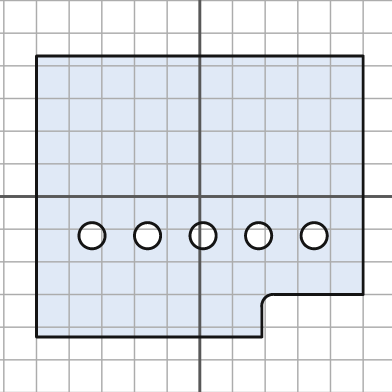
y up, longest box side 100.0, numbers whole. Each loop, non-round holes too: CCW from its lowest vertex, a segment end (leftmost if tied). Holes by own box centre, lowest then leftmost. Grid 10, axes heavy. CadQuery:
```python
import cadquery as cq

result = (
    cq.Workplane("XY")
    .moveTo(-50.0, -43.0)
    .lineTo(19.0, -43.0)
    .lineTo(19.0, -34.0)
    .threePointArc((20.0, -31.0), (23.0, -30.0))
    .lineTo(50.0, -30.0)
    .lineTo(50.0, 43.0)
    .lineTo(-50.0, 43.0)
    .close()
    .moveTo(-33.0, -12.0)
    .circle(4.0)
    .moveTo(-16.0, -12.0)
    .circle(4.0)
    .moveTo(1.0, -12.0)
    .circle(4.0)
    .moveTo(18.0, -12.0)
    .circle(4.0)
    .moveTo(35.0, -12.0)
    .circle(4.0)
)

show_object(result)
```